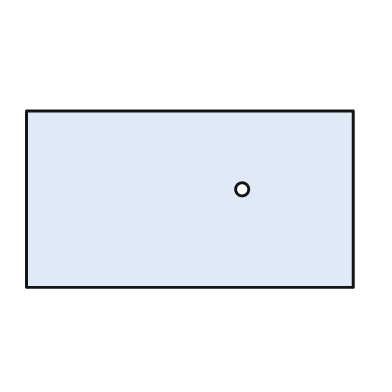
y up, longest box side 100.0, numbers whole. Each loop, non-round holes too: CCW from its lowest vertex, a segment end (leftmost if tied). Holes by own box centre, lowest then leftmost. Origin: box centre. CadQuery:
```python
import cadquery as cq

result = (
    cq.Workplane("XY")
    .moveTo(-50.0, -27.0)
    .lineTo(50.0, -27.0)
    .lineTo(50.0, 27.0)
    .lineTo(-50.0, 27.0)
    .close()
    .moveTo(16.0, 3.0)
    .circle(2.0)
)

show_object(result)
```